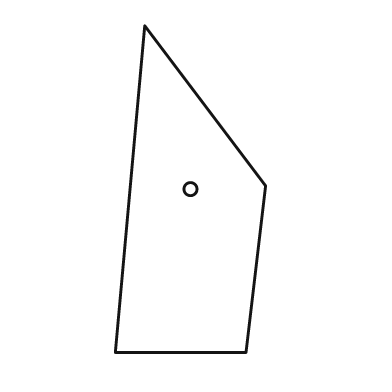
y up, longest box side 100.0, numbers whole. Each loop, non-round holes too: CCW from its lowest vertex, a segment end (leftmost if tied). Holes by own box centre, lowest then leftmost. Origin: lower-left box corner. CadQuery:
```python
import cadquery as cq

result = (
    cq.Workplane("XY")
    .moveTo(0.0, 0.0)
    .lineTo(40.0, 0.0)
    .lineTo(46.0, 51.0)
    .lineTo(9.0, 100.0)
    .close()
    .moveTo(23.0, 50.0)
    .circle(2.0)
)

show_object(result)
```